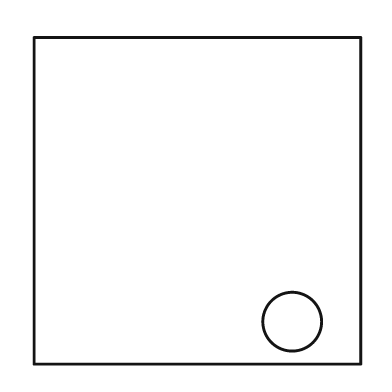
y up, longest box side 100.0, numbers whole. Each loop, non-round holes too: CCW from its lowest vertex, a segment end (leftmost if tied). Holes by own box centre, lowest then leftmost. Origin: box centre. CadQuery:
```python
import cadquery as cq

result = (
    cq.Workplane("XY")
    .moveTo(-50.0, -50.0)
    .lineTo(50.0, -50.0)
    .lineTo(50.0, 50.0)
    .lineTo(-50.0, 50.0)
    .close()
    .moveTo(29.0, -37.0)
    .circle(9.0)
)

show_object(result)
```